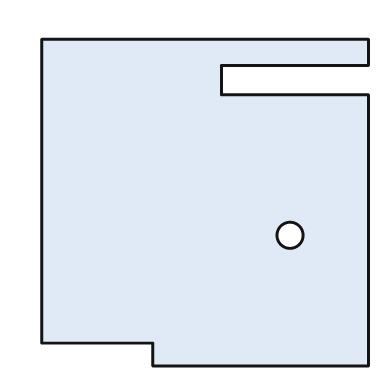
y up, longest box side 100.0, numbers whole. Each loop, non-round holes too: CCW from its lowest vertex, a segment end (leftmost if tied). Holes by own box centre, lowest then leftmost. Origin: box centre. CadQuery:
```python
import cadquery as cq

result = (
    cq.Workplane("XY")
    .moveTo(-16.0, -50.0)
    .lineTo(50.0, -50.0)
    .lineTo(50.0, 33.0)
    .lineTo(5.0, 33.0)
    .lineTo(5.0, 42.0)
    .lineTo(50.0, 42.0)
    .lineTo(50.0, 50.0)
    .lineTo(-50.0, 50.0)
    .lineTo(-50.0, -43.0)
    .lineTo(-16.0, -43.0)
    .close()
    .moveTo(26.0, -10.0)
    .circle(4.0)
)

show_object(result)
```